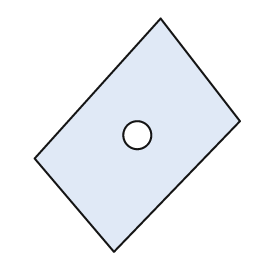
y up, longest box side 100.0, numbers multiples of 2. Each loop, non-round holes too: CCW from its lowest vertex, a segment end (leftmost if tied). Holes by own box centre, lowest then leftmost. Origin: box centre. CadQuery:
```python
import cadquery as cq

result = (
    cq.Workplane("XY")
    .moveTo(-10.0, -50.0)
    .lineTo(44.0, 6.0)
    .lineTo(10.0, 50.0)
    .lineTo(-44.0, -10.0)
    .close()
    .moveTo(0.0, 0.0)
    .circle(6.0)
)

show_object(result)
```